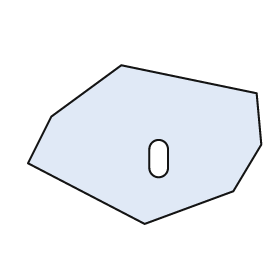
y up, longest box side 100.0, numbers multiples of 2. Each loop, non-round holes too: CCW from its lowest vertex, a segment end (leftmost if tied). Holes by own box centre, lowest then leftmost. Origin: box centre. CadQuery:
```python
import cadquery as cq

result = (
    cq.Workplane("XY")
    .moveTo(0.0, -34.0)
    .lineTo(38.0, -20.0)
    .lineTo(50.0, 0.0)
    .lineTo(48.0, 22.0)
    .lineTo(-10.0, 34.0)
    .lineTo(-40.0, 12.0)
    .lineTo(-50.0, -8.0)
    .close()
    .moveTo(2.0, -10.0)
    .threePointArc((6.0, -14.0), (10.0, -10.0))
    .lineTo(10.0, -2.0)
    .threePointArc((6.0, 2.0), (2.0, -2.0))
    .close()
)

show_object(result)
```